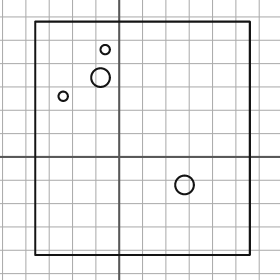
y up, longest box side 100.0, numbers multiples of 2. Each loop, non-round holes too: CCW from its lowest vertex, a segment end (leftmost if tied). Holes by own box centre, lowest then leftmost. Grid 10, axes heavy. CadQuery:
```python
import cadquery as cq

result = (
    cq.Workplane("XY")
    .moveTo(-36.0, -42.0)
    .lineTo(56.0, -42.0)
    .lineTo(56.0, 58.0)
    .lineTo(-36.0, 58.0)
    .close()
    .moveTo(28.0, -12.0)
    .circle(4.0)
    .moveTo(-24.0, 26.0)
    .circle(2.0)
    .moveTo(-8.0, 34.0)
    .circle(4.0)
    .moveTo(-6.0, 46.0)
    .circle(2.0)
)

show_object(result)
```